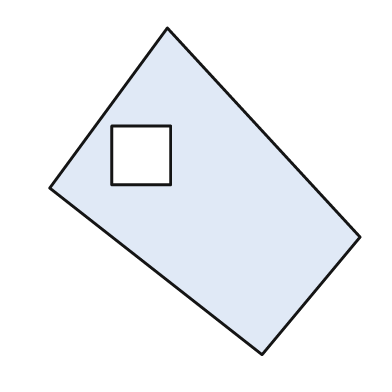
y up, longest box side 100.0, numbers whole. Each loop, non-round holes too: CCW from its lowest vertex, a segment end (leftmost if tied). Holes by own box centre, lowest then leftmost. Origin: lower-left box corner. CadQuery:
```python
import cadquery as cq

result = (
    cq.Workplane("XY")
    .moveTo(65.0, 0.0)
    .lineTo(95.0, 36.0)
    .lineTo(36.0, 100.0)
    .lineTo(0.0, 51.0)
    .close()
    .moveTo(19.0, 52.0)
    .lineTo(37.0, 52.0)
    .lineTo(37.0, 70.0)
    .lineTo(19.0, 70.0)
    .close()
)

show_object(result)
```